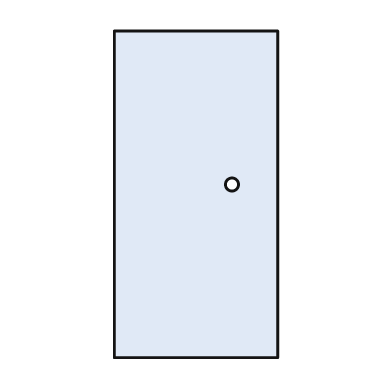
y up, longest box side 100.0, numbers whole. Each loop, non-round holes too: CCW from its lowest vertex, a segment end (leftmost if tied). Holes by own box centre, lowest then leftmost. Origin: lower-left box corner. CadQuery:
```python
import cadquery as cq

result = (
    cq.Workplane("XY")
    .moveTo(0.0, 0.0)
    .lineTo(50.0, 0.0)
    .lineTo(50.0, 100.0)
    .lineTo(0.0, 100.0)
    .close()
    .moveTo(36.0, 53.0)
    .circle(2.0)
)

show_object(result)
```